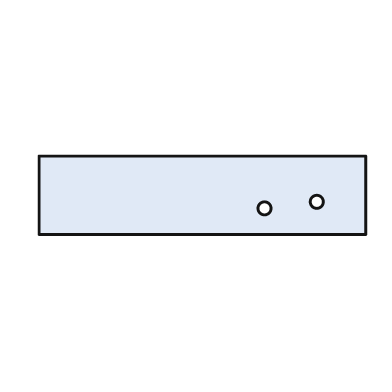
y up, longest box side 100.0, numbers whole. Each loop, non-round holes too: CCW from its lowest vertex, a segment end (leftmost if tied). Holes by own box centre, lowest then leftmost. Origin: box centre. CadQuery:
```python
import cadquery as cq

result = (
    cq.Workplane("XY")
    .moveTo(-50.0, -12.0)
    .lineTo(50.0, -12.0)
    .lineTo(50.0, 12.0)
    .lineTo(-50.0, 12.0)
    .close()
    .moveTo(19.0, -4.0)
    .circle(2.0)
    .moveTo(35.0, -2.0)
    .circle(2.0)
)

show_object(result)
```